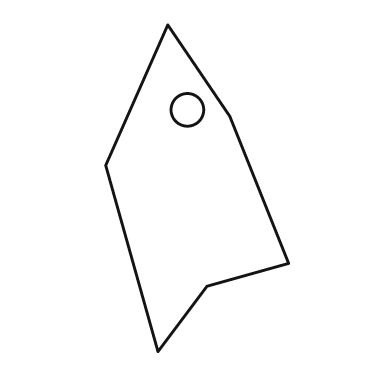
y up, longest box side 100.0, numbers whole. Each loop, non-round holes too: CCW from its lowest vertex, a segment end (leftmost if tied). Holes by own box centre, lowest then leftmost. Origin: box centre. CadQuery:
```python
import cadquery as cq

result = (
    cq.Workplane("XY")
    .moveTo(-12.0, -50.0)
    .lineTo(3.0, -30.0)
    .lineTo(28.0, -23.0)
    .lineTo(10.0, 22.0)
    .lineTo(-9.0, 50.0)
    .lineTo(-28.0, 7.0)
    .close()
    .moveTo(-3.0, 24.0)
    .circle(5.0)
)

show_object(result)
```